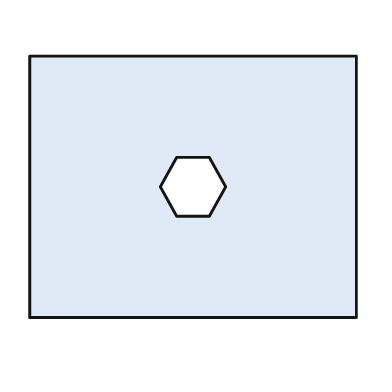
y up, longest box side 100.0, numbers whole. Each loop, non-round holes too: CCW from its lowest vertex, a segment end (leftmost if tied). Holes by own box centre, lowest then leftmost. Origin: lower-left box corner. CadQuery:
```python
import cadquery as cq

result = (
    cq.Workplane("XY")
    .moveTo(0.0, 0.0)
    .lineTo(100.0, 0.0)
    .lineTo(100.0, 80.0)
    .lineTo(0.0, 80.0)
    .close()
    .moveTo(45.0, 31.0)
    .lineTo(55.0, 31.0)
    .lineTo(60.0, 40.0)
    .lineTo(55.0, 49.0)
    .lineTo(45.0, 49.0)
    .lineTo(40.0, 40.0)
    .close()
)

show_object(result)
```